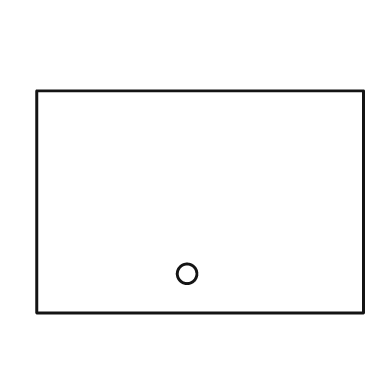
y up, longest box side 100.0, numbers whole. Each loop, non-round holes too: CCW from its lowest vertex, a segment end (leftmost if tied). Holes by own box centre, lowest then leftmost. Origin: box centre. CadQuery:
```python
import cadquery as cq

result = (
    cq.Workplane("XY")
    .moveTo(-50.0, -34.0)
    .lineTo(50.0, -34.0)
    .lineTo(50.0, 34.0)
    .lineTo(-50.0, 34.0)
    .close()
    .moveTo(-4.0, -22.0)
    .circle(3.0)
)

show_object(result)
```